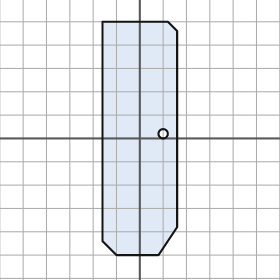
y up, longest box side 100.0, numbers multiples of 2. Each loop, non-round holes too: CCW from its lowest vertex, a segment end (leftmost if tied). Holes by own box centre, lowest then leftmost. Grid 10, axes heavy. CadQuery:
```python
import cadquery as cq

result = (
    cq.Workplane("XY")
    .moveTo(-10.0, -50.0)
    .lineTo(8.0, -50.0)
    .lineTo(16.0, -38.0)
    .lineTo(16.0, 46.0)
    .lineTo(12.0, 50.0)
    .lineTo(-16.0, 50.0)
    .lineTo(-16.0, -44.0)
    .close()
    .moveTo(10.0, 2.0)
    .circle(2.0)
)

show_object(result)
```